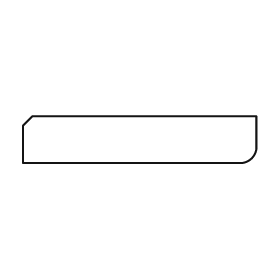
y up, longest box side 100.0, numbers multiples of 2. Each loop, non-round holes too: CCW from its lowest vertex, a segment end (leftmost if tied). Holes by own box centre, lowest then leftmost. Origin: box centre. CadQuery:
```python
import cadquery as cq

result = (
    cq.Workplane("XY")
    .moveTo(-50.0, -10.0)
    .lineTo(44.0, -10.0)
    .threePointArc((48.0, -8.0), (50.0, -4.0))
    .lineTo(50.0, 10.0)
    .lineTo(-46.0, 10.0)
    .lineTo(-50.0, 6.0)
    .close()
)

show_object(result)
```